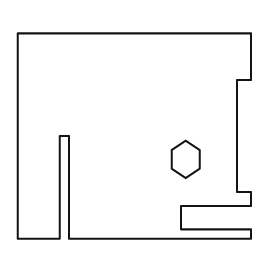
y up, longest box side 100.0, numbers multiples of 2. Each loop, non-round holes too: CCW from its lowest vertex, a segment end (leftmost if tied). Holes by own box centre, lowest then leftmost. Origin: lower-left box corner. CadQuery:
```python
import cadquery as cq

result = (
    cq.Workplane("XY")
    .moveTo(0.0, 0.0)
    .lineTo(18.0, 0.0)
    .lineTo(18.0, 44.0)
    .lineTo(22.0, 44.0)
    .lineTo(22.0, 0.0)
    .lineTo(100.0, 0.0)
    .lineTo(100.0, 4.0)
    .lineTo(70.0, 4.0)
    .lineTo(70.0, 14.0)
    .lineTo(100.0, 14.0)
    .lineTo(100.0, 20.0)
    .lineTo(94.0, 20.0)
    .lineTo(94.0, 68.0)
    .lineTo(100.0, 68.0)
    .lineTo(100.0, 88.0)
    .lineTo(0.0, 88.0)
    .close()
    .moveTo(72.0, 26.0)
    .lineTo(78.0, 30.0)
    .lineTo(78.0, 38.0)
    .lineTo(72.0, 42.0)
    .lineTo(66.0, 38.0)
    .lineTo(66.0, 30.0)
    .close()
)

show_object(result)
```